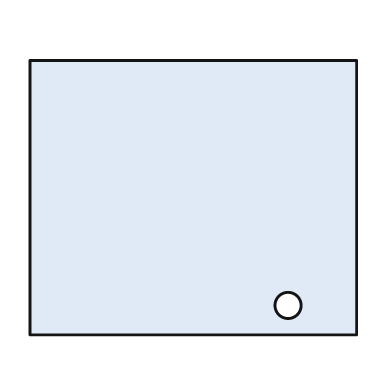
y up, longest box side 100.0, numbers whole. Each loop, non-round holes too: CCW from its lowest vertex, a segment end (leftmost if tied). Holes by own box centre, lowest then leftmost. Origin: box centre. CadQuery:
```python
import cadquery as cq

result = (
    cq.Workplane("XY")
    .moveTo(-50.0, -42.0)
    .lineTo(50.0, -42.0)
    .lineTo(50.0, 42.0)
    .lineTo(-50.0, 42.0)
    .close()
    .moveTo(29.0, -33.0)
    .circle(4.0)
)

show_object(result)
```